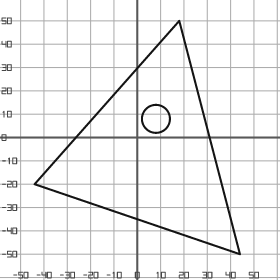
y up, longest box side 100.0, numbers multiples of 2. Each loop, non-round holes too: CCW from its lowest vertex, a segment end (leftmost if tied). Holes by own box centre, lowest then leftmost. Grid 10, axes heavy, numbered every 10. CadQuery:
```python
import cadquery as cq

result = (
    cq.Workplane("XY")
    .moveTo(44.0, -50.0)
    .lineTo(18.0, 50.0)
    .lineTo(-44.0, -20.0)
    .close()
    .moveTo(8.0, 8.0)
    .circle(6.0)
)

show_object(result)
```